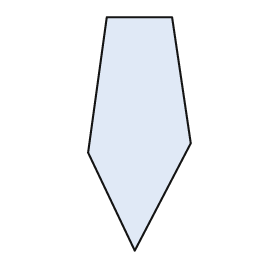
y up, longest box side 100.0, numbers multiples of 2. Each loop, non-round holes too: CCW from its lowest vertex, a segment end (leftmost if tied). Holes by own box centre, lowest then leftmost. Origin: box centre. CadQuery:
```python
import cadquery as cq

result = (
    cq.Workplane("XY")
    .moveTo(-2.0, -50.0)
    .lineTo(22.0, -4.0)
    .lineTo(14.0, 50.0)
    .lineTo(-14.0, 50.0)
    .lineTo(-22.0, -8.0)
    .close()
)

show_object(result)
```